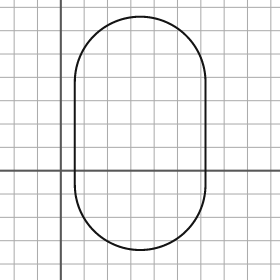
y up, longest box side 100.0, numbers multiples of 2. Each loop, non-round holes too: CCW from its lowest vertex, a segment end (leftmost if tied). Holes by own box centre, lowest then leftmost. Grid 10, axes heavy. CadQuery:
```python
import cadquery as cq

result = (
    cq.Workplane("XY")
    .moveTo(6.0, -6.0)
    .threePointArc((34.0, -34.0), (62.0, -6.0))
    .lineTo(62.0, 38.0)
    .threePointArc((34.0, 66.0), (6.0, 38.0))
    .close()
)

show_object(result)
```